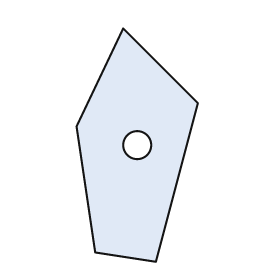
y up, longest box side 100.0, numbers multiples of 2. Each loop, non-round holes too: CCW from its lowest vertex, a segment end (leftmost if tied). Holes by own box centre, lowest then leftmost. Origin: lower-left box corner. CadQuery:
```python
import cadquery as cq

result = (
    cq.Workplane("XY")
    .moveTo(34.0, 0.0)
    .lineTo(52.0, 68.0)
    .lineTo(20.0, 100.0)
    .lineTo(0.0, 58.0)
    .lineTo(8.0, 4.0)
    .close()
    .moveTo(26.0, 50.0)
    .circle(6.0)
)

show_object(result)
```